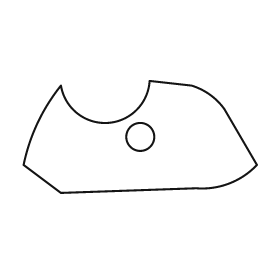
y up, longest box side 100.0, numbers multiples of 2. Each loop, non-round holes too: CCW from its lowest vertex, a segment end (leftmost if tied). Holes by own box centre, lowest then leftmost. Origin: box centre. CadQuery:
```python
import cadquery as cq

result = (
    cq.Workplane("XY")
    .moveTo(-34.0, -24.0)
    .lineTo(24.0, -22.0)
    .threePointArc((38.0, -20.0), (50.0, -12.0))
    .lineTo(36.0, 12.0)
    .threePointArc((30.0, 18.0), (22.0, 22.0))
    .lineTo(4.0, 24.0)
    .threePointArc((-14.0, 6.0), (-34.0, 22.0))
    .threePointArc((-44.0, 6.0), (-50.0, -12.0))
    .close()
    .moveTo(0.0, 0.0)
    .circle(6.0)
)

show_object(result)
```